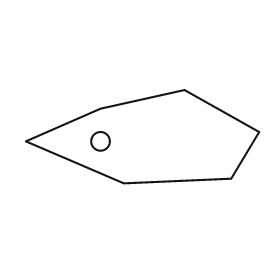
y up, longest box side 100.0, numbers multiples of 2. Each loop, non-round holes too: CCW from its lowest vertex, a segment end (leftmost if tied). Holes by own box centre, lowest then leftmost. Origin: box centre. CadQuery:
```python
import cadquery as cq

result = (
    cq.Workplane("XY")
    .moveTo(-8.0, -20.0)
    .lineTo(38.0, -18.0)
    .lineTo(50.0, 2.0)
    .lineTo(18.0, 20.0)
    .lineTo(-18.0, 12.0)
    .lineTo(-50.0, -2.0)
    .close()
    .moveTo(-18.0, -2.0)
    .circle(4.0)
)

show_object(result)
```